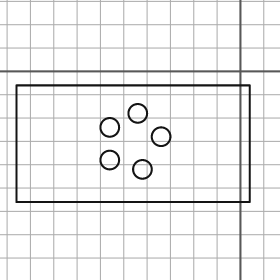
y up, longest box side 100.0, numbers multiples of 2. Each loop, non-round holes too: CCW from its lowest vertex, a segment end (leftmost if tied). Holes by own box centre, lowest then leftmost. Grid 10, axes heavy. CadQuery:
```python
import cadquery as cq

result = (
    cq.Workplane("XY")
    .moveTo(-96.0, -56.0)
    .lineTo(4.0, -56.0)
    .lineTo(4.0, -6.0)
    .lineTo(-96.0, -6.0)
    .close()
    .moveTo(-42.0, -42.0)
    .circle(4.0)
    .moveTo(-56.0, -38.0)
    .circle(4.0)
    .moveTo(-34.0, -28.0)
    .circle(4.0)
    .moveTo(-56.0, -24.0)
    .circle(4.0)
    .moveTo(-44.0, -18.0)
    .circle(4.0)
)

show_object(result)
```